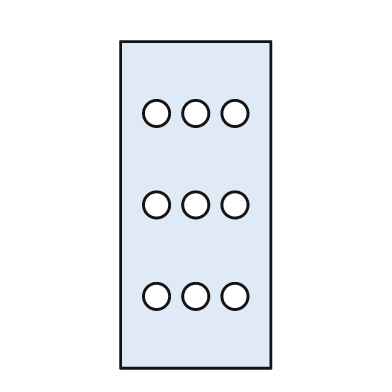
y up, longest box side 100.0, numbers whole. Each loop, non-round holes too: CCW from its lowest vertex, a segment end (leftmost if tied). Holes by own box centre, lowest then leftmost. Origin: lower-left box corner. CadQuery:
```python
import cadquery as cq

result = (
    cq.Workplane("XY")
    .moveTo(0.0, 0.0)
    .lineTo(46.0, 0.0)
    .lineTo(46.0, 100.0)
    .lineTo(0.0, 100.0)
    .close()
    .moveTo(11.0, 22.0)
    .circle(4.0)
    .moveTo(23.0, 22.0)
    .circle(4.0)
    .moveTo(35.0, 22.0)
    .circle(4.0)
    .moveTo(11.0, 50.0)
    .circle(4.0)
    .moveTo(23.0, 50.0)
    .circle(4.0)
    .moveTo(35.0, 50.0)
    .circle(4.0)
    .moveTo(11.0, 78.0)
    .circle(4.0)
    .moveTo(23.0, 78.0)
    .circle(4.0)
    .moveTo(35.0, 78.0)
    .circle(4.0)
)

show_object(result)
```